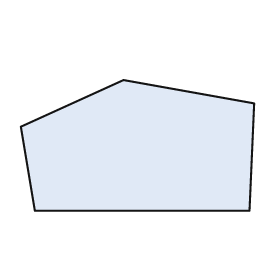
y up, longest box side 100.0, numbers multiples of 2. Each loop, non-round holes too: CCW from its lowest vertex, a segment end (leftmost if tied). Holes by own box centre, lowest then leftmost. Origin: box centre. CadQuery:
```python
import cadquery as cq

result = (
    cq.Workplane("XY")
    .moveTo(-44.0, -28.0)
    .lineTo(48.0, -28.0)
    .lineTo(50.0, 18.0)
    .lineTo(-6.0, 28.0)
    .lineTo(-50.0, 8.0)
    .close()
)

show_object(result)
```